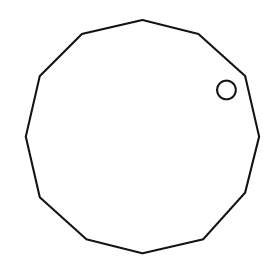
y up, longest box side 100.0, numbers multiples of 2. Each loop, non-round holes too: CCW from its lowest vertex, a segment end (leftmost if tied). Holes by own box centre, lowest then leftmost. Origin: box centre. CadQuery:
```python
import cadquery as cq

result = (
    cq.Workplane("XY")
    .moveTo(0.0, -50.0)
    .lineTo(26.0, -44.0)
    .lineTo(44.0, -24.0)
    .lineTo(50.0, 0.0)
    .lineTo(44.0, 26.0)
    .lineTo(24.0, 44.0)
    .lineTo(0.0, 50.0)
    .lineTo(-26.0, 44.0)
    .lineTo(-44.0, 26.0)
    .lineTo(-50.0, 0.0)
    .lineTo(-44.0, -26.0)
    .lineTo(-24.0, -44.0)
    .close()
    .moveTo(36.0, 20.0)
    .circle(4.0)
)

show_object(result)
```